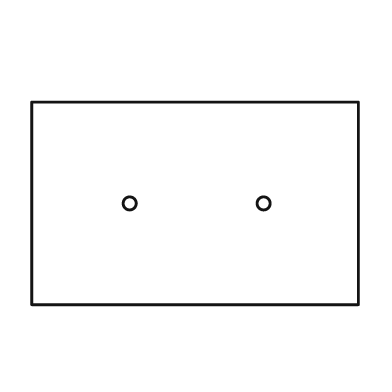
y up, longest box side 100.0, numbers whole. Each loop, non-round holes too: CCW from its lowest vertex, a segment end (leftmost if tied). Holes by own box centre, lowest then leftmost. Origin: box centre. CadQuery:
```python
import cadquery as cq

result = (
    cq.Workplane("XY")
    .moveTo(-50.0, -31.0)
    .lineTo(50.0, -31.0)
    .lineTo(50.0, 31.0)
    .lineTo(-50.0, 31.0)
    .close()
    .moveTo(-20.0, 0.0)
    .circle(2.0)
    .moveTo(21.0, 0.0)
    .circle(2.0)
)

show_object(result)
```